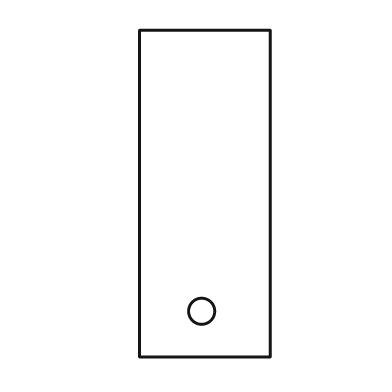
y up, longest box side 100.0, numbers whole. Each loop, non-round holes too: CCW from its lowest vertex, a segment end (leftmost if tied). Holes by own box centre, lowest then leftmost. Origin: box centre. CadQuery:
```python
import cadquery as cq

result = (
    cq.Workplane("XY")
    .moveTo(-20.0, -50.0)
    .lineTo(20.0, -50.0)
    .lineTo(20.0, 50.0)
    .lineTo(-20.0, 50.0)
    .close()
    .moveTo(-1.0, -36.0)
    .circle(4.0)
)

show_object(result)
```